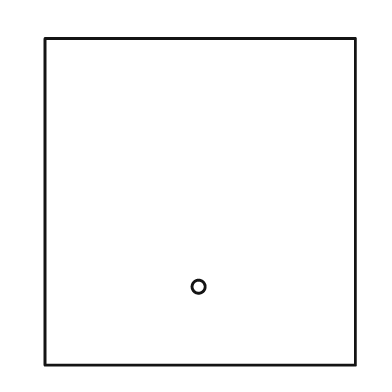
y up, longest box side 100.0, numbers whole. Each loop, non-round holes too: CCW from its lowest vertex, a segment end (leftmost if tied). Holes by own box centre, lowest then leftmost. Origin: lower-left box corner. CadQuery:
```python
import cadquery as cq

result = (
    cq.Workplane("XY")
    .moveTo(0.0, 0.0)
    .lineTo(95.0, 0.0)
    .lineTo(95.0, 100.0)
    .lineTo(0.0, 100.0)
    .close()
    .moveTo(47.0, 24.0)
    .circle(2.0)
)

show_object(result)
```